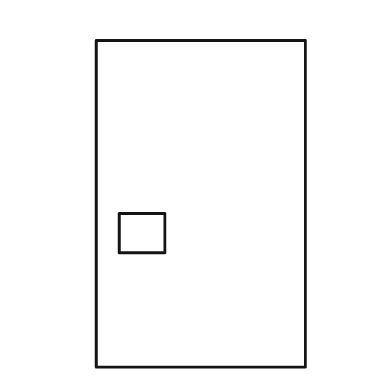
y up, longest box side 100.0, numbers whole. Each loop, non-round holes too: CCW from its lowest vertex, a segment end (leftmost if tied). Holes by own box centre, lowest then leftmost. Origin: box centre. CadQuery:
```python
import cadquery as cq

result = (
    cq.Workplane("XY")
    .moveTo(-32.0, -50.0)
    .lineTo(32.0, -50.0)
    .lineTo(32.0, 50.0)
    .lineTo(-32.0, 50.0)
    .close()
    .moveTo(-25.0, -15.0)
    .lineTo(-11.0, -15.0)
    .lineTo(-11.0, -3.0)
    .lineTo(-25.0, -3.0)
    .close()
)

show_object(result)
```